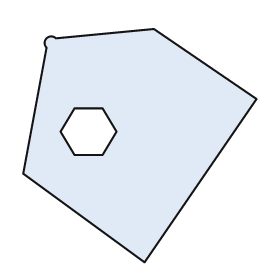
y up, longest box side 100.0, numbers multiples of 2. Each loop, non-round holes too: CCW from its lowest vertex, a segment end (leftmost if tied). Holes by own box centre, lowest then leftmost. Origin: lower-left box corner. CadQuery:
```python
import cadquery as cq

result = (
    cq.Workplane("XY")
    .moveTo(52.0, 0.0)
    .lineTo(100.0, 70.0)
    .lineTo(56.0, 100.0)
    .lineTo(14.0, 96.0)
    .threePointArc((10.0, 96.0), (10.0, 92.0))
    .lineTo(0.0, 38.0)
    .close()
    .moveTo(22.0, 46.0)
    .lineTo(34.0, 46.0)
    .lineTo(40.0, 56.0)
    .lineTo(34.0, 66.0)
    .lineTo(22.0, 66.0)
    .lineTo(16.0, 56.0)
    .close()
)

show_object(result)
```